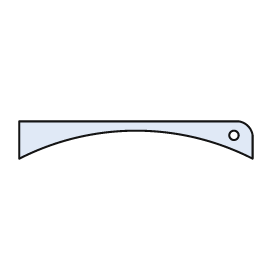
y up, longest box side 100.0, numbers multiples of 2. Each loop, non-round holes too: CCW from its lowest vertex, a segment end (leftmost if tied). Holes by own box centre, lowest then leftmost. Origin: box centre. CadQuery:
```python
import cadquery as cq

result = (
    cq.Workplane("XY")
    .moveTo(-50.0, -8.0)
    .threePointArc((0.0, 4.0), (50.0, -8.0))
    .lineTo(50.0, 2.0)
    .threePointArc((48.0, 6.0), (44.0, 8.0))
    .lineTo(-50.0, 8.0)
    .close()
    .moveTo(42.0, 2.0)
    .circle(2.0)
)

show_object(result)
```